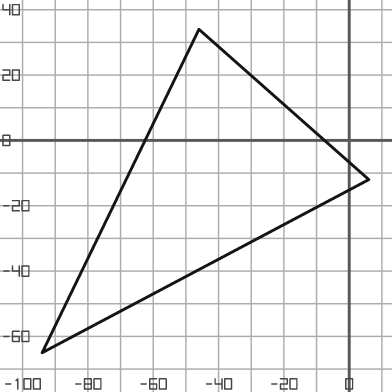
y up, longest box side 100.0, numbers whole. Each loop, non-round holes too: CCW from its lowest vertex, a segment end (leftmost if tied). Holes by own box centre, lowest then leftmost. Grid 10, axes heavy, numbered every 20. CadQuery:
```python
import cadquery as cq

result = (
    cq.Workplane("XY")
    .moveTo(-94.0, -65.0)
    .lineTo(6.0, -12.0)
    .lineTo(-46.0, 34.0)
    .close()
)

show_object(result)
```